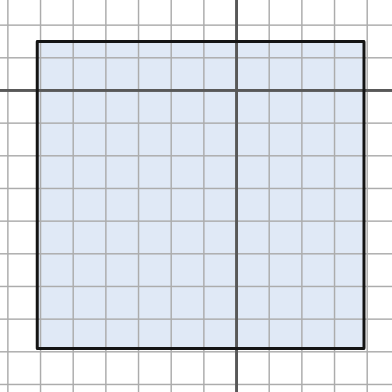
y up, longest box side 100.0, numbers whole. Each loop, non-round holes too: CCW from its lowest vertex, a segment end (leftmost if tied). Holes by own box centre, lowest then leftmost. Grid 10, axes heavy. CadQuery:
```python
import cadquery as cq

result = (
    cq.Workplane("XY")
    .moveTo(-61.0, -79.0)
    .lineTo(39.0, -79.0)
    .lineTo(39.0, 15.0)
    .lineTo(-61.0, 15.0)
    .close()
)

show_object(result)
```